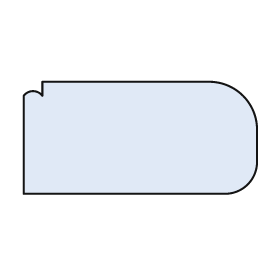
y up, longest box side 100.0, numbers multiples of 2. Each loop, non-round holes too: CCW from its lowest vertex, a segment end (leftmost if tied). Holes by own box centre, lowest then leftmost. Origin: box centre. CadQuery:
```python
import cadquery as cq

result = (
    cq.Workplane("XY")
    .moveTo(-50.0, -24.0)
    .lineTo(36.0, -24.0)
    .threePointArc((46.0, -20.0), (50.0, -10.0))
    .lineTo(50.0, 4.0)
    .threePointArc((44.0, 18.0), (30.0, 24.0))
    .lineTo(-42.0, 24.0)
    .lineTo(-42.0, 18.0)
    .threePointArc((-46.0, 20.0), (-50.0, 18.0))
    .close()
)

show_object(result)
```